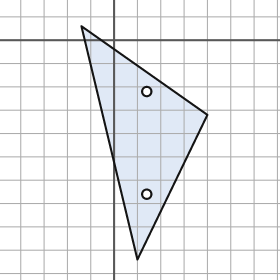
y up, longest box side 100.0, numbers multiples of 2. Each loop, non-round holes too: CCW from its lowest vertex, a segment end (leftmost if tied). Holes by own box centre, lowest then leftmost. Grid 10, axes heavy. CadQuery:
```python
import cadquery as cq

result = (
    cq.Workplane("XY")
    .moveTo(10.0, -94.0)
    .lineTo(40.0, -32.0)
    .lineTo(-14.0, 6.0)
    .close()
    .moveTo(14.0, -66.0)
    .circle(2.0)
    .moveTo(14.0, -22.0)
    .circle(2.0)
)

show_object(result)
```